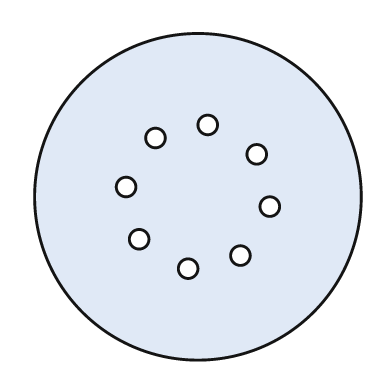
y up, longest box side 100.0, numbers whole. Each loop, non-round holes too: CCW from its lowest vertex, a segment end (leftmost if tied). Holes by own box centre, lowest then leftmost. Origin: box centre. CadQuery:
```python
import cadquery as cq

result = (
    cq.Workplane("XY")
    .moveTo(0.0, 0.0)
    .circle(50.0)
    .moveTo(-3.0, -22.0)
    .circle(3.0)
    .moveTo(13.0, -18.0)
    .circle(3.0)
    .moveTo(-18.0, -13.0)
    .circle(3.0)
    .moveTo(22.0, -3.0)
    .circle(3.0)
    .moveTo(-22.0, 3.0)
    .circle(3.0)
    .moveTo(18.0, 13.0)
    .circle(3.0)
    .moveTo(-13.0, 18.0)
    .circle(3.0)
    .moveTo(3.0, 22.0)
    .circle(3.0)
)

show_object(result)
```